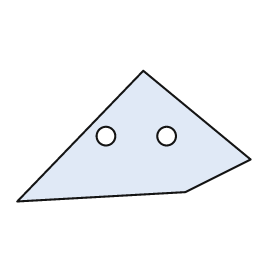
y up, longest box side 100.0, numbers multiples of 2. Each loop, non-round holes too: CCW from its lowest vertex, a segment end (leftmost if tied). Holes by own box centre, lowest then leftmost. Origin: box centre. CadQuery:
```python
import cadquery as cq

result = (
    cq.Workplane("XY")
    .moveTo(-50.0, -28.0)
    .lineTo(22.0, -24.0)
    .lineTo(50.0, -10.0)
    .lineTo(4.0, 28.0)
    .close()
    .moveTo(-12.0, 0.0)
    .circle(4.0)
    .moveTo(14.0, 0.0)
    .circle(4.0)
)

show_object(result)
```